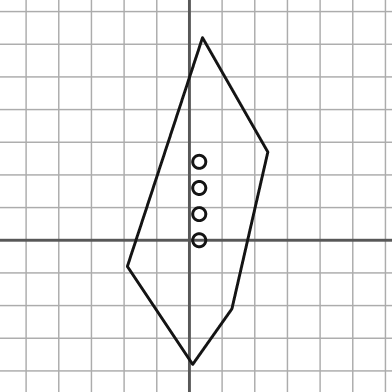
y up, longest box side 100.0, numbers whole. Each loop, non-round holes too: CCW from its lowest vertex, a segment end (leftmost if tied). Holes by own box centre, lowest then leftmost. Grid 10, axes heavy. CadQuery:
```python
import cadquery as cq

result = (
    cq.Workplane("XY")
    .moveTo(1.0, -38.0)
    .lineTo(13.0, -21.0)
    .lineTo(24.0, 27.0)
    .lineTo(4.0, 62.0)
    .lineTo(-19.0, -8.0)
    .close()
    .moveTo(3.0, 0.0)
    .circle(2.0)
    .moveTo(3.0, 8.0)
    .circle(2.0)
    .moveTo(3.0, 16.0)
    .circle(2.0)
    .moveTo(3.0, 24.0)
    .circle(2.0)
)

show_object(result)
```